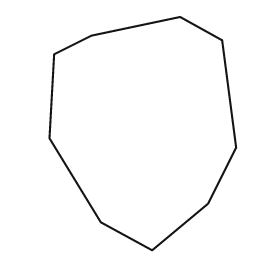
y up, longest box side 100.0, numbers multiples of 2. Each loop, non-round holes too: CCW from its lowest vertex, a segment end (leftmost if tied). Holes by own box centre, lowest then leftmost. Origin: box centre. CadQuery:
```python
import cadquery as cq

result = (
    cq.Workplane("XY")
    .moveTo(4.0, -50.0)
    .lineTo(28.0, -30.0)
    .lineTo(40.0, -6.0)
    .lineTo(34.0, 40.0)
    .lineTo(16.0, 50.0)
    .lineTo(-22.0, 42.0)
    .lineTo(-38.0, 34.0)
    .lineTo(-40.0, -2.0)
    .lineTo(-18.0, -38.0)
    .close()
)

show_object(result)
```